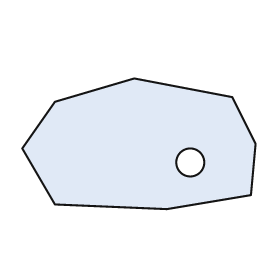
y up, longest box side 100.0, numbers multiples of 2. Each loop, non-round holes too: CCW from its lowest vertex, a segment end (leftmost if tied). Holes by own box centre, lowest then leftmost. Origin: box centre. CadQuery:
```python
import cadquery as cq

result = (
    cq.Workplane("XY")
    .moveTo(12.0, -28.0)
    .lineTo(48.0, -22.0)
    .lineTo(50.0, 0.0)
    .lineTo(40.0, 20.0)
    .lineTo(-2.0, 28.0)
    .lineTo(-36.0, 18.0)
    .lineTo(-50.0, -2.0)
    .lineTo(-36.0, -26.0)
    .close()
    .moveTo(22.0, -8.0)
    .circle(6.0)
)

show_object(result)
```